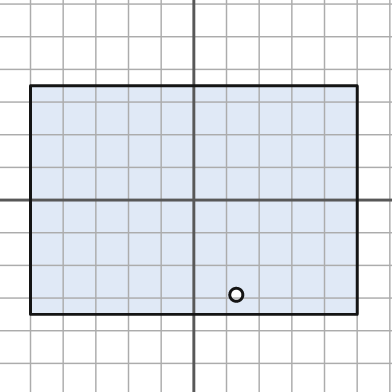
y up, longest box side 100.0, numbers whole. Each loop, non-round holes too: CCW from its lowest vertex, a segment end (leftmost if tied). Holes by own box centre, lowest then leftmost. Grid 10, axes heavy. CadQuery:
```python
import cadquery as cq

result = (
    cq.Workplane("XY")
    .moveTo(-50.0, -35.0)
    .lineTo(50.0, -35.0)
    .lineTo(50.0, 35.0)
    .lineTo(-50.0, 35.0)
    .close()
    .moveTo(13.0, -29.0)
    .circle(2.0)
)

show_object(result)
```